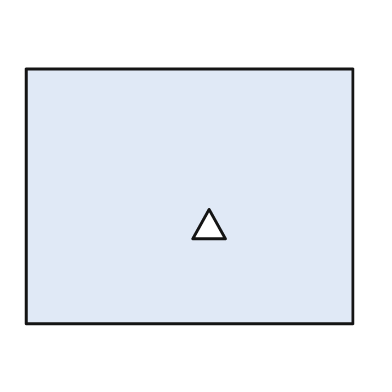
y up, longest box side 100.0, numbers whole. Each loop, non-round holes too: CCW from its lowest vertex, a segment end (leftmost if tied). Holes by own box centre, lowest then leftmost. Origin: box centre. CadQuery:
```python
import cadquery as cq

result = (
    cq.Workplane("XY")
    .moveTo(-50.0, -39.0)
    .lineTo(50.0, -39.0)
    .lineTo(50.0, 39.0)
    .lineTo(-50.0, 39.0)
    .close()
    .moveTo(1.0, -13.0)
    .lineTo(11.0, -13.0)
    .lineTo(6.0, -4.0)
    .close()
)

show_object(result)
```